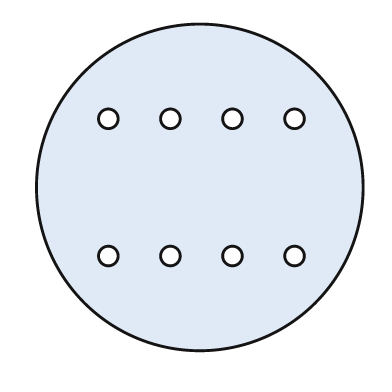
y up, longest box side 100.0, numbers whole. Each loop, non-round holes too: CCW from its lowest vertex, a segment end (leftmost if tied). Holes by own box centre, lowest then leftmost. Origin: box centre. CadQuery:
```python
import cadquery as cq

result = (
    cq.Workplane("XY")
    .moveTo(0.0, 0.0)
    .circle(50.0)
    .moveTo(-28.0, -21.0)
    .circle(3.0)
    .moveTo(-9.0, -21.0)
    .circle(3.0)
    .moveTo(10.0, -21.0)
    .circle(3.0)
    .moveTo(29.0, -21.0)
    .circle(3.0)
    .moveTo(-28.0, 21.0)
    .circle(3.0)
    .moveTo(-9.0, 21.0)
    .circle(3.0)
    .moveTo(10.0, 21.0)
    .circle(3.0)
    .moveTo(29.0, 21.0)
    .circle(3.0)
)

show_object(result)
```